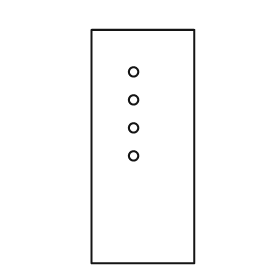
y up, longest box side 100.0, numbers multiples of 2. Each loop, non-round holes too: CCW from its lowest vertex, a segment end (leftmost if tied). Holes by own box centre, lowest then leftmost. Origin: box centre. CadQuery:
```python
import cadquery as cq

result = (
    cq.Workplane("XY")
    .moveTo(-22.0, -50.0)
    .lineTo(22.0, -50.0)
    .lineTo(22.0, 50.0)
    .lineTo(-22.0, 50.0)
    .close()
    .moveTo(-4.0, -4.0)
    .circle(2.0)
    .moveTo(-4.0, 8.0)
    .circle(2.0)
    .moveTo(-4.0, 20.0)
    .circle(2.0)
    .moveTo(-4.0, 32.0)
    .circle(2.0)
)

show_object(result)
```